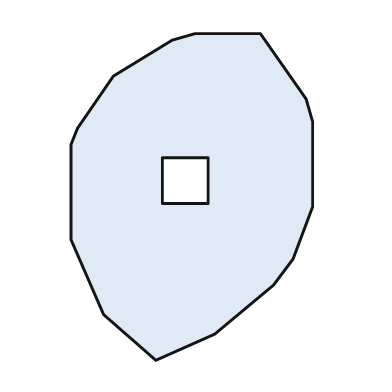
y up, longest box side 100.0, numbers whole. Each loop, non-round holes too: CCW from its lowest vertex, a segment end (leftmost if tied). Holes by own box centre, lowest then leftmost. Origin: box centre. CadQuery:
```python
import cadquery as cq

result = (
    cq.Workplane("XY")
    .moveTo(-11.0, -50.0)
    .lineTo(7.0, -42.0)
    .lineTo(25.0, -27.0)
    .lineTo(31.0, -19.0)
    .lineTo(37.0, -3.0)
    .lineTo(37.0, 23.0)
    .lineTo(35.0, 30.0)
    .lineTo(21.0, 50.0)
    .lineTo(1.0, 50.0)
    .lineTo(-6.0, 48.0)
    .lineTo(-24.0, 37.0)
    .lineTo(-35.0, 21.0)
    .lineTo(-37.0, 16.0)
    .lineTo(-37.0, -13.0)
    .lineTo(-27.0, -36.0)
    .close()
    .moveTo(-9.0, -2.0)
    .lineTo(5.0, -2.0)
    .lineTo(5.0, 12.0)
    .lineTo(-9.0, 12.0)
    .close()
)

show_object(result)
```